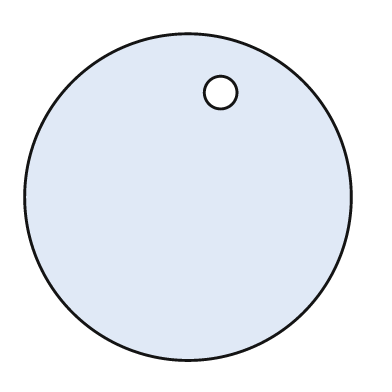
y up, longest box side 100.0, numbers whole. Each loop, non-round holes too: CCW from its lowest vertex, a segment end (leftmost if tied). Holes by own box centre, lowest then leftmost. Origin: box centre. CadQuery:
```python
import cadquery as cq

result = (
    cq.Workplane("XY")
    .moveTo(0.0, 0.0)
    .circle(50.0)
    .moveTo(10.0, 32.0)
    .circle(5.0)
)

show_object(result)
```